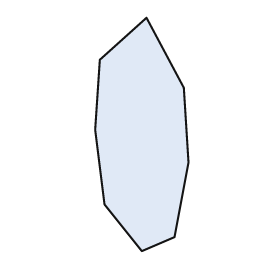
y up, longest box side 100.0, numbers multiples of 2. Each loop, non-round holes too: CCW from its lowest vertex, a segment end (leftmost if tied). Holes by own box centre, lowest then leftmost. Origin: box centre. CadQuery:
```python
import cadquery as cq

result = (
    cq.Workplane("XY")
    .moveTo(0.0, -50.0)
    .lineTo(14.0, -44.0)
    .lineTo(20.0, -12.0)
    .lineTo(18.0, 20.0)
    .lineTo(2.0, 50.0)
    .lineTo(-18.0, 32.0)
    .lineTo(-20.0, 2.0)
    .lineTo(-16.0, -30.0)
    .close()
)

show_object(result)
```